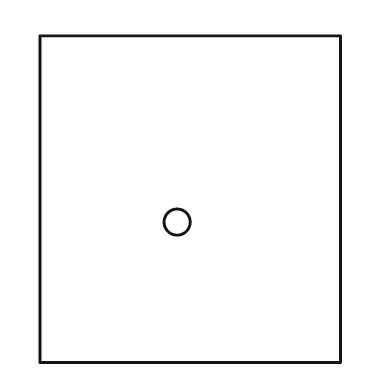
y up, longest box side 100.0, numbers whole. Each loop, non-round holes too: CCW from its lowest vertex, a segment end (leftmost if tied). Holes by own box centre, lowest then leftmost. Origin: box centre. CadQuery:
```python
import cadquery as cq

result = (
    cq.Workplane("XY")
    .moveTo(-46.0, -50.0)
    .lineTo(46.0, -50.0)
    .lineTo(46.0, 50.0)
    .lineTo(-46.0, 50.0)
    .close()
    .moveTo(-4.0, -7.0)
    .circle(4.0)
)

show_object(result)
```